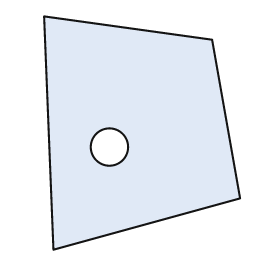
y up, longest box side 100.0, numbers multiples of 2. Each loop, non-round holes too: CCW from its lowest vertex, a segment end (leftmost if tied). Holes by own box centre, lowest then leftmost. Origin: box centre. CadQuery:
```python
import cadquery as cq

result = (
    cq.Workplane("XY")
    .moveTo(-38.0, -50.0)
    .lineTo(42.0, -28.0)
    .lineTo(30.0, 40.0)
    .lineTo(-42.0, 50.0)
    .close()
    .moveTo(-14.0, -6.0)
    .circle(8.0)
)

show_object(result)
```